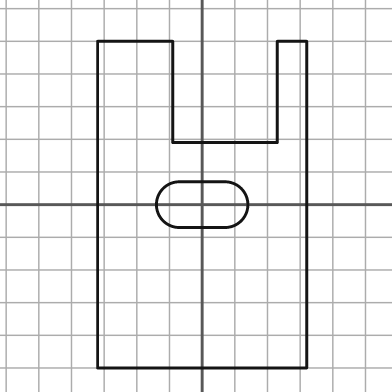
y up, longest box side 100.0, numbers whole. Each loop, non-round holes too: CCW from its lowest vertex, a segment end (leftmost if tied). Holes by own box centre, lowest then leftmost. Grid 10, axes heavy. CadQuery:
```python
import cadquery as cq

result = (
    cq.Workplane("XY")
    .moveTo(-32.0, -50.0)
    .lineTo(32.0, -50.0)
    .lineTo(32.0, 50.0)
    .lineTo(23.0, 50.0)
    .lineTo(23.0, 19.0)
    .lineTo(-9.0, 19.0)
    .lineTo(-9.0, 50.0)
    .lineTo(-32.0, 50.0)
    .close()
    .moveTo(-7.0, -7.0)
    .lineTo(7.0, -7.0)
    .threePointArc((14.0, 0.0), (7.0, 7.0))
    .lineTo(-7.0, 7.0)
    .threePointArc((-14.0, 0.0), (-7.0, -7.0))
    .close()
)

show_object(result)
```